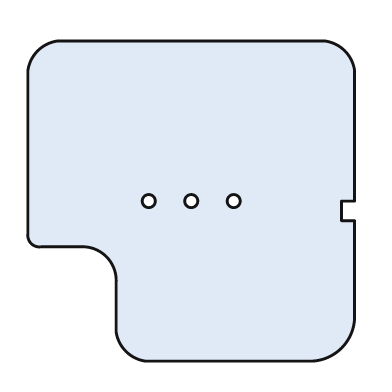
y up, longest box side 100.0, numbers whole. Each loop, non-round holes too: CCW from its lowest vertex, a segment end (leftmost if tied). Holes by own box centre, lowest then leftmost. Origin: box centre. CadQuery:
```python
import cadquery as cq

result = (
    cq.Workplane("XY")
    .moveTo(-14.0, -49.0)
    .lineTo(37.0, -49.0)
    .threePointArc((46.0, -45.0), (50.0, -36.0))
    .lineTo(50.0, -6.0)
    .lineTo(46.0, -6.0)
    .lineTo(46.0, 0.0)
    .lineTo(50.0, 0.0)
    .lineTo(50.0, 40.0)
    .threePointArc((47.0, 46.0), (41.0, 49.0))
    .lineTo(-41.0, 49.0)
    .threePointArc((-47.0, 46.0), (-50.0, 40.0))
    .lineTo(-50.0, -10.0)
    .threePointArc((-49.0, -13.0), (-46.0, -14.0))
    .lineTo(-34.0, -14.0)
    .threePointArc((-26.0, -17.0), (-23.0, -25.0))
    .lineTo(-23.0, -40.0)
    .threePointArc((-20.0, -46.0), (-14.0, -49.0))
    .close()
    .moveTo(-13.0, 0.0)
    .circle(2.0)
    .moveTo(0.0, 0.0)
    .circle(2.0)
    .moveTo(13.0, 0.0)
    .circle(2.0)
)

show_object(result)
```